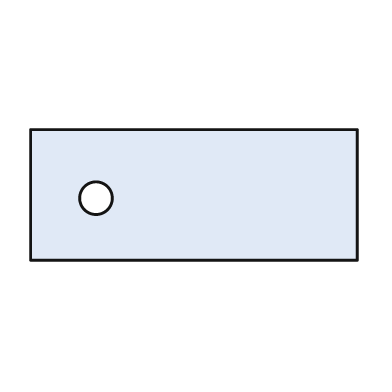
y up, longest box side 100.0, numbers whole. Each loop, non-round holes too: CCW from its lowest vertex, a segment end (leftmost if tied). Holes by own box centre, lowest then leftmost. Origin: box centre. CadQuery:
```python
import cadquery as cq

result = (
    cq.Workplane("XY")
    .moveTo(-50.0, -20.0)
    .lineTo(50.0, -20.0)
    .lineTo(50.0, 20.0)
    .lineTo(-50.0, 20.0)
    .close()
    .moveTo(-30.0, -1.0)
    .circle(5.0)
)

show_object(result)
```